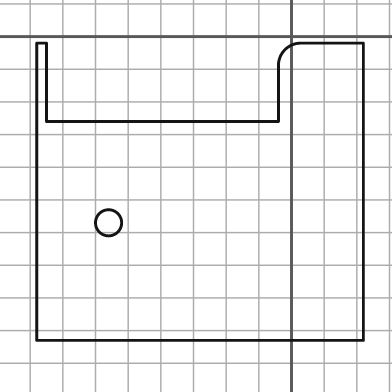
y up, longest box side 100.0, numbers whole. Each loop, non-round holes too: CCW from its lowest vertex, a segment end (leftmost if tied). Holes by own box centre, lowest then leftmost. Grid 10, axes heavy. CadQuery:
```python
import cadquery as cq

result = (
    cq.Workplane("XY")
    .moveTo(-78.0, -93.0)
    .lineTo(22.0, -93.0)
    .lineTo(22.0, -2.0)
    .lineTo(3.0, -2.0)
    .threePointArc((-2.0, -4.0), (-4.0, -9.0))
    .lineTo(-4.0, -26.0)
    .lineTo(-75.0, -26.0)
    .lineTo(-75.0, -2.0)
    .lineTo(-78.0, -2.0)
    .close()
    .moveTo(-56.0, -57.0)
    .circle(4.0)
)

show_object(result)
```